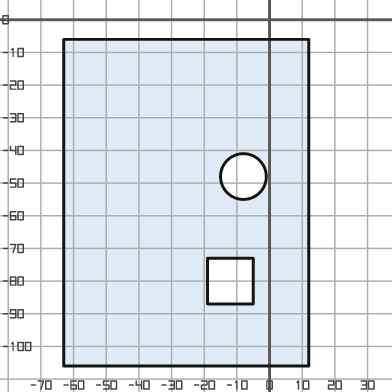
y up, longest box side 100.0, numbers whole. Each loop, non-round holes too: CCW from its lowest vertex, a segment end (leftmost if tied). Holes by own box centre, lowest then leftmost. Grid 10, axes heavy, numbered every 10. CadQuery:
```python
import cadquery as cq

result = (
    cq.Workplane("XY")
    .moveTo(-63.0, -106.0)
    .lineTo(12.0, -106.0)
    .lineTo(12.0, -6.0)
    .lineTo(-63.0, -6.0)
    .close()
    .moveTo(-19.0, -87.0)
    .lineTo(-5.0, -87.0)
    .lineTo(-5.0, -73.0)
    .lineTo(-19.0, -73.0)
    .close()
    .moveTo(-8.0, -48.0)
    .circle(7.0)
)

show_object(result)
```